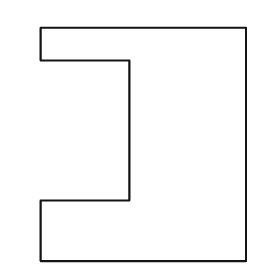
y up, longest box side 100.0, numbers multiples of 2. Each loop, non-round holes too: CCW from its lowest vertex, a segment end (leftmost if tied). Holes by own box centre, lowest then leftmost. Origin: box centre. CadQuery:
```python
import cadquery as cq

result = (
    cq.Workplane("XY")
    .moveTo(-44.0, -50.0)
    .lineTo(44.0, -50.0)
    .lineTo(44.0, 50.0)
    .lineTo(-44.0, 50.0)
    .lineTo(-44.0, 36.0)
    .lineTo(-6.0, 36.0)
    .lineTo(-6.0, -24.0)
    .lineTo(-44.0, -24.0)
    .close()
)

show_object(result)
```